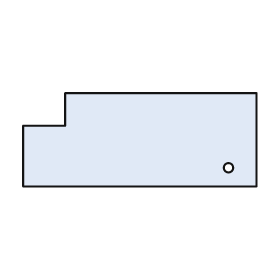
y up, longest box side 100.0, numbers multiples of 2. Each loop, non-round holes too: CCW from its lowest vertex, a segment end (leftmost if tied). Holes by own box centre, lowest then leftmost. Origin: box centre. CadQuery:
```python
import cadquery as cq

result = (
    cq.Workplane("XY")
    .moveTo(-50.0, -20.0)
    .lineTo(50.0, -20.0)
    .lineTo(50.0, 20.0)
    .lineTo(-32.0, 20.0)
    .lineTo(-32.0, 6.0)
    .lineTo(-50.0, 6.0)
    .close()
    .moveTo(38.0, -12.0)
    .circle(2.0)
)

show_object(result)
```